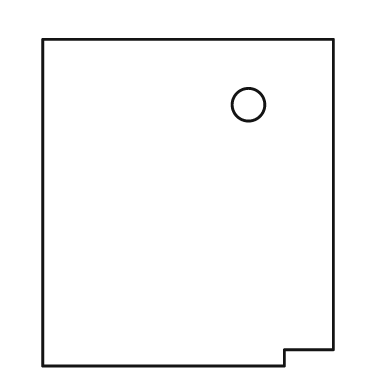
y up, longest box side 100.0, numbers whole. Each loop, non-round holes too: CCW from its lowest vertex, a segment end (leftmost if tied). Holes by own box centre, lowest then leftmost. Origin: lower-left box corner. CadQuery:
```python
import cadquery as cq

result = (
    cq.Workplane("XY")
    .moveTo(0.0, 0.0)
    .lineTo(74.0, 0.0)
    .lineTo(74.0, 5.0)
    .lineTo(89.0, 5.0)
    .lineTo(89.0, 100.0)
    .lineTo(0.0, 100.0)
    .close()
    .moveTo(63.0, 80.0)
    .circle(5.0)
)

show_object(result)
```